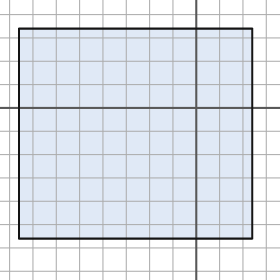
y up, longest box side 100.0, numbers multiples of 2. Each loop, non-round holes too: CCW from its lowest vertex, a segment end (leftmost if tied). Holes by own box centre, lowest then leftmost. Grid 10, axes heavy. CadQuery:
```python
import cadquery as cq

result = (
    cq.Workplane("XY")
    .moveTo(-76.0, -56.0)
    .lineTo(24.0, -56.0)
    .lineTo(24.0, 34.0)
    .lineTo(-76.0, 34.0)
    .close()
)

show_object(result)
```